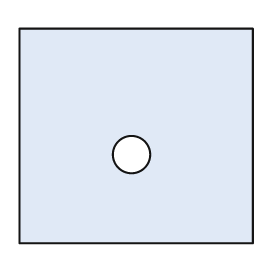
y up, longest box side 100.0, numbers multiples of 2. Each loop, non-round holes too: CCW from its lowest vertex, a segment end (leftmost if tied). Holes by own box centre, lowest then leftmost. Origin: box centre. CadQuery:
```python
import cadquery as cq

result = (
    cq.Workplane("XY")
    .moveTo(-50.0, -46.0)
    .lineTo(50.0, -46.0)
    .lineTo(50.0, 46.0)
    .lineTo(-50.0, 46.0)
    .close()
    .moveTo(-2.0, -8.0)
    .circle(8.0)
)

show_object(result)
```